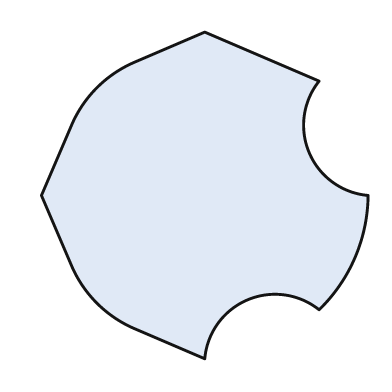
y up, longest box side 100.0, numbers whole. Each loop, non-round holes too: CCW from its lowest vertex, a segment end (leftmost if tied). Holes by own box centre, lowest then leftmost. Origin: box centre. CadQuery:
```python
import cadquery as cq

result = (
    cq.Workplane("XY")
    .moveTo(0.0, -50.0)
    .threePointArc((13.0, -32.0), (35.0, -35.0))
    .threePointArc((46.0, -19.0), (50.0, 0.0))
    .threePointArc((32.0, 13.0), (35.0, 35.0))
    .lineTo(0.0, 50.0)
    .lineTo(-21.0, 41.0)
    .threePointArc((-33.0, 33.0), (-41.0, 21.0))
    .lineTo(-50.0, 0.0)
    .lineTo(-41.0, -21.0)
    .threePointArc((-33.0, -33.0), (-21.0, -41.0))
    .close()
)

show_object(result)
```